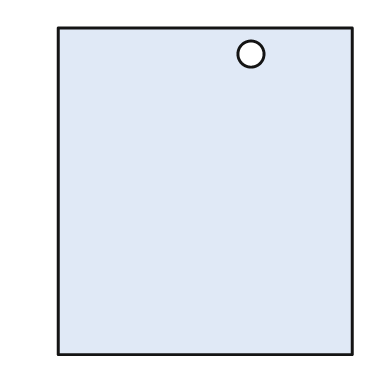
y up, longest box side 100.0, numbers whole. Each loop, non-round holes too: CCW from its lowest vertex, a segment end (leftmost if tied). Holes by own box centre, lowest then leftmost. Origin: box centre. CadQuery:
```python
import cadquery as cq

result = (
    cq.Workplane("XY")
    .moveTo(-45.0, -50.0)
    .lineTo(45.0, -50.0)
    .lineTo(45.0, 50.0)
    .lineTo(-45.0, 50.0)
    .close()
    .moveTo(14.0, 42.0)
    .circle(4.0)
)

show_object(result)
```